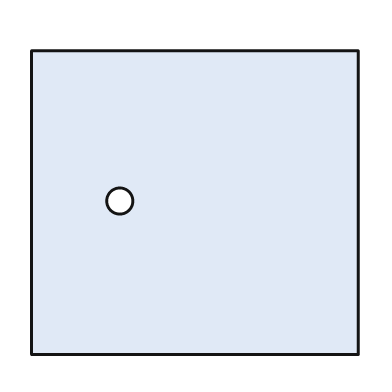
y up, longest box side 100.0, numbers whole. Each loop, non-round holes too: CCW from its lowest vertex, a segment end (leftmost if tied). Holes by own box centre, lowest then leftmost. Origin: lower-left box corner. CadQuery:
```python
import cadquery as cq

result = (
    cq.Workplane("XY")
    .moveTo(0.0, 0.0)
    .lineTo(100.0, 0.0)
    .lineTo(100.0, 93.0)
    .lineTo(0.0, 93.0)
    .close()
    .moveTo(27.0, 47.0)
    .circle(4.0)
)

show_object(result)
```